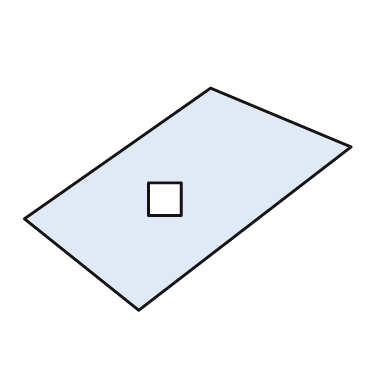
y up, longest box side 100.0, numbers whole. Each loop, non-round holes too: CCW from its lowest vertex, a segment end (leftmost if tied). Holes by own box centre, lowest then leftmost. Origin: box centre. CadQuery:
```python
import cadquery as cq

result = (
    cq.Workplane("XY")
    .moveTo(-15.0, -34.0)
    .lineTo(50.0, 16.0)
    .lineTo(7.0, 34.0)
    .lineTo(-50.0, -6.0)
    .close()
    .moveTo(-12.0, -5.0)
    .lineTo(-2.0, -5.0)
    .lineTo(-2.0, 5.0)
    .lineTo(-12.0, 5.0)
    .close()
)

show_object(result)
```